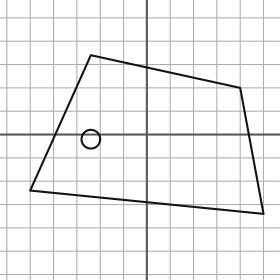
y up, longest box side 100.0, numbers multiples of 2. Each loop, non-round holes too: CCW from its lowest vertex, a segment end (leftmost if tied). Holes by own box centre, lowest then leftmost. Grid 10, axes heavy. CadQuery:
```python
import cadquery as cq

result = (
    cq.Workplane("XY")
    .moveTo(50.0, -34.0)
    .lineTo(40.0, 20.0)
    .lineTo(-24.0, 34.0)
    .lineTo(-50.0, -24.0)
    .close()
    .moveTo(-24.0, -2.0)
    .circle(4.0)
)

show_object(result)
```